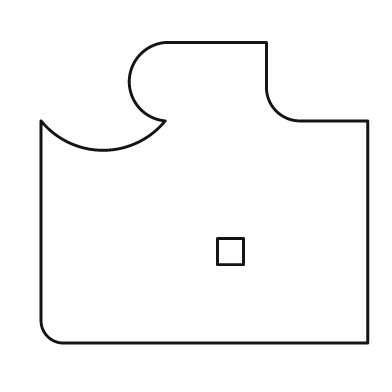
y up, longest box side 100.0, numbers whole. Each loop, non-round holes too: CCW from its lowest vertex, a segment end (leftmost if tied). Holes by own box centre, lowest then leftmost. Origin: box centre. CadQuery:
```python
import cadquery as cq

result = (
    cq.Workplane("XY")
    .moveTo(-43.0, -46.0)
    .lineTo(50.0, -46.0)
    .lineTo(50.0, 22.0)
    .lineTo(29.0, 22.0)
    .threePointArc((22.0, 25.0), (19.0, 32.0))
    .lineTo(19.0, 46.0)
    .lineTo(-12.0, 46.0)
    .threePointArc((-23.0, 34.0), (-12.0, 22.0))
    .threePointArc((-31.0, 13.0), (-50.0, 22.0))
    .lineTo(-50.0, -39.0)
    .threePointArc((-48.0, -44.0), (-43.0, -46.0))
    .close()
    .moveTo(4.0, -22.0)
    .lineTo(12.0, -22.0)
    .lineTo(12.0, -14.0)
    .lineTo(4.0, -14.0)
    .close()
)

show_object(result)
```